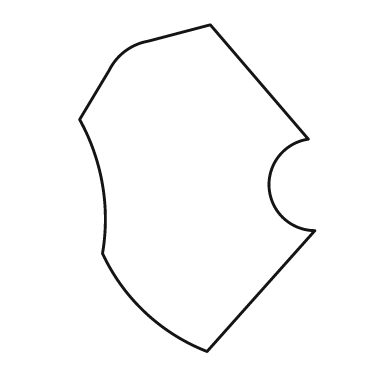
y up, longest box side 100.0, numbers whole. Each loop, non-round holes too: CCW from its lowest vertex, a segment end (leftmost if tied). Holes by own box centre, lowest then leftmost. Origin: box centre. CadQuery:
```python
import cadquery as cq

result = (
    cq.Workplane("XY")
    .moveTo(3.0, -50.0)
    .lineTo(36.0, -13.0)
    .threePointArc((22.0, 0.0), (34.0, 15.0))
    .lineTo(4.0, 50.0)
    .lineTo(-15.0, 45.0)
    .threePointArc((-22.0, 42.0), (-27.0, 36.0))
    .lineTo(-36.0, 21.0)
    .threePointArc((-29.0, 1.0), (-29.0, -20.0))
    .threePointArc((-16.0, -38.0), (3.0, -50.0))
    .close()
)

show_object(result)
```